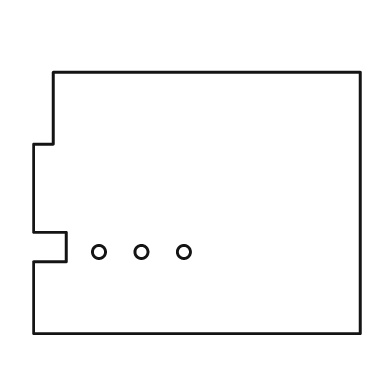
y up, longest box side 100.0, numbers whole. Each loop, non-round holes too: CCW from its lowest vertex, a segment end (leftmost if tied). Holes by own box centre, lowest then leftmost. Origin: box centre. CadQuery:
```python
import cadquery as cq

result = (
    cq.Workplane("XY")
    .moveTo(-50.0, -40.0)
    .lineTo(50.0, -40.0)
    .lineTo(50.0, 40.0)
    .lineTo(-44.0, 40.0)
    .lineTo(-44.0, 18.0)
    .lineTo(-50.0, 18.0)
    .lineTo(-50.0, -9.0)
    .lineTo(-40.0, -9.0)
    .lineTo(-40.0, -18.0)
    .lineTo(-50.0, -18.0)
    .close()
    .moveTo(-30.0, -15.0)
    .circle(2.0)
    .moveTo(-17.0, -15.0)
    .circle(2.0)
    .moveTo(-4.0, -15.0)
    .circle(2.0)
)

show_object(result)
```